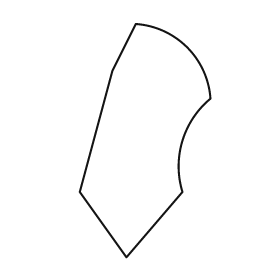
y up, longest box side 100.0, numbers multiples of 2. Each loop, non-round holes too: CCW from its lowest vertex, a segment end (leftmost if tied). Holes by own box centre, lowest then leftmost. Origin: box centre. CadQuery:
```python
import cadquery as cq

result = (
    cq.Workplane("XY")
    .moveTo(-8.0, -50.0)
    .lineTo(16.0, -22.0)
    .threePointArc((16.0, 0.0), (28.0, 18.0))
    .threePointArc((18.0, 40.0), (-4.0, 50.0))
    .lineTo(-14.0, 30.0)
    .lineTo(-28.0, -22.0)
    .close()
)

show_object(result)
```